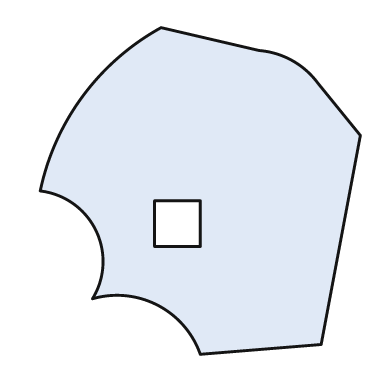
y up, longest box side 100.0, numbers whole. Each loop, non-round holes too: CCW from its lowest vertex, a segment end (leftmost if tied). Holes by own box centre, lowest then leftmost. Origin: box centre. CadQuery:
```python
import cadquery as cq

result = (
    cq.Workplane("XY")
    .moveTo(0.0, -50.0)
    .lineTo(37.0, -47.0)
    .lineTo(49.0, 17.0)
    .lineTo(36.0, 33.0)
    .threePointArc((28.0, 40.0), (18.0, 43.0))
    .lineTo(-12.0, 50.0)
    .threePointArc((-36.0, 29.0), (-49.0, 0.0))
    .threePointArc((-32.0, -12.0), (-33.0, -33.0))
    .threePointArc((-13.0, -35.0), (0.0, -50.0))
    .close()
    .moveTo(-14.0, -17.0)
    .lineTo(0.0, -17.0)
    .lineTo(0.0, -3.0)
    .lineTo(-14.0, -3.0)
    .close()
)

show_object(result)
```